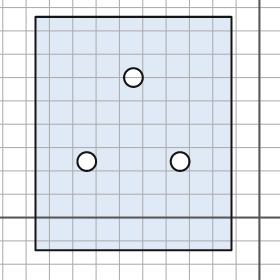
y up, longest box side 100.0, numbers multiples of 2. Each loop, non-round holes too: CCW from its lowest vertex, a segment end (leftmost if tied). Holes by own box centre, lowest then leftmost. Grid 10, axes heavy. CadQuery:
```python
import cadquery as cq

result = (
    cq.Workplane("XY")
    .moveTo(-96.0, -14.0)
    .lineTo(-12.0, -14.0)
    .lineTo(-12.0, 86.0)
    .lineTo(-96.0, 86.0)
    .close()
    .moveTo(-74.0, 24.0)
    .circle(4.0)
    .moveTo(-34.0, 24.0)
    .circle(4.0)
    .moveTo(-54.0, 60.0)
    .circle(4.0)
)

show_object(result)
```